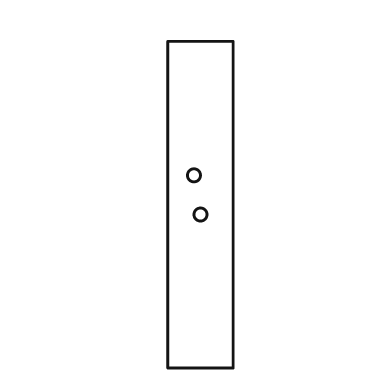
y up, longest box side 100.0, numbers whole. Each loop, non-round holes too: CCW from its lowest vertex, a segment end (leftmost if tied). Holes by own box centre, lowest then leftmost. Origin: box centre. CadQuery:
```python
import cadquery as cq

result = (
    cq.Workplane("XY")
    .moveTo(-10.0, -50.0)
    .lineTo(10.0, -50.0)
    .lineTo(10.0, 50.0)
    .lineTo(-10.0, 50.0)
    .close()
    .moveTo(0.0, -3.0)
    .circle(2.0)
    .moveTo(-2.0, 9.0)
    .circle(2.0)
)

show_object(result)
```